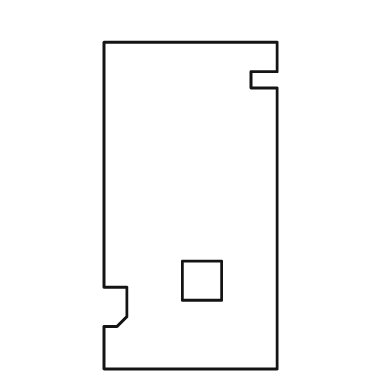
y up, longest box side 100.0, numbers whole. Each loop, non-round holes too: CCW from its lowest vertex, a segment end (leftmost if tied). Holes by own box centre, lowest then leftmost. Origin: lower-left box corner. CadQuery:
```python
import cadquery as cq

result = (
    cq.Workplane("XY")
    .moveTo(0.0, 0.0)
    .lineTo(53.0, 0.0)
    .lineTo(53.0, 86.0)
    .lineTo(45.0, 86.0)
    .lineTo(45.0, 91.0)
    .lineTo(53.0, 91.0)
    .lineTo(53.0, 100.0)
    .lineTo(0.0, 100.0)
    .lineTo(0.0, 25.0)
    .lineTo(7.0, 25.0)
    .lineTo(7.0, 16.0)
    .lineTo(4.0, 13.0)
    .lineTo(0.0, 13.0)
    .close()
    .moveTo(24.0, 21.0)
    .lineTo(36.0, 21.0)
    .lineTo(36.0, 33.0)
    .lineTo(24.0, 33.0)
    .close()
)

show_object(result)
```